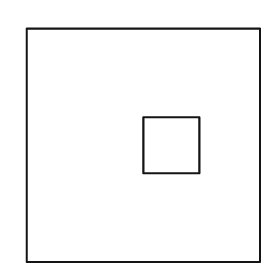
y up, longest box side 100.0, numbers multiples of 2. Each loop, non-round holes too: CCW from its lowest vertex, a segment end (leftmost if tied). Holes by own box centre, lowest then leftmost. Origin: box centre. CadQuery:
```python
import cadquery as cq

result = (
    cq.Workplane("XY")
    .moveTo(-50.0, -50.0)
    .lineTo(50.0, -50.0)
    .lineTo(50.0, 50.0)
    .lineTo(-50.0, 50.0)
    .close()
    .moveTo(0.0, -12.0)
    .lineTo(24.0, -12.0)
    .lineTo(24.0, 12.0)
    .lineTo(0.0, 12.0)
    .close()
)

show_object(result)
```